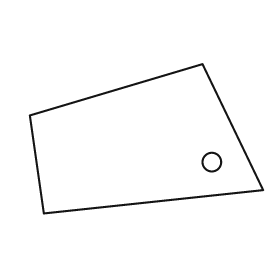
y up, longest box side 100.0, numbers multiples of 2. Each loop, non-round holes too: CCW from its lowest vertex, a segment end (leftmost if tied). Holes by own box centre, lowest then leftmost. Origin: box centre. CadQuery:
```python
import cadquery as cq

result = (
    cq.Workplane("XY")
    .moveTo(-44.0, -32.0)
    .lineTo(50.0, -22.0)
    .lineTo(24.0, 32.0)
    .lineTo(-50.0, 10.0)
    .close()
    .moveTo(28.0, -10.0)
    .circle(4.0)
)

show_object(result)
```